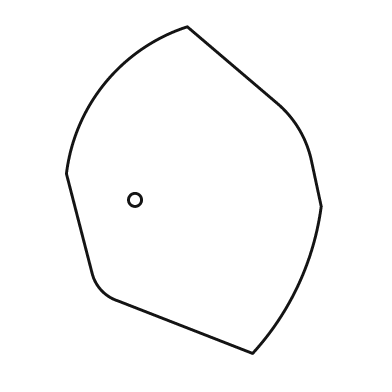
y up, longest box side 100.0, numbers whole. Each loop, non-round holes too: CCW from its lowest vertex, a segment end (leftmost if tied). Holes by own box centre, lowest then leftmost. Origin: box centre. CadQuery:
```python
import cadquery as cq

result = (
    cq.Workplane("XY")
    .moveTo(18.0, -50.0)
    .threePointArc((32.0, -29.0), (39.0, -5.0))
    .lineTo(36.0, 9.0)
    .threePointArc((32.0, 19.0), (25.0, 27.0))
    .lineTo(-2.0, 50.0)
    .threePointArc((-27.0, 33.0), (-39.0, 5.0))
    .lineTo(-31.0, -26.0)
    .threePointArc((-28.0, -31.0), (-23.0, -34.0))
    .close()
    .moveTo(-18.0, -3.0)
    .circle(2.0)
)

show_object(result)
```